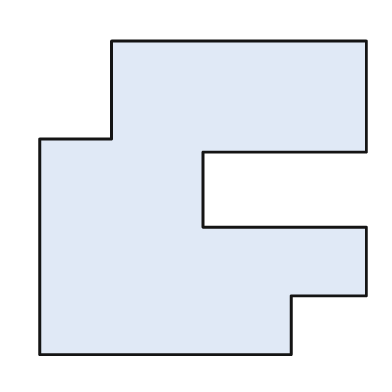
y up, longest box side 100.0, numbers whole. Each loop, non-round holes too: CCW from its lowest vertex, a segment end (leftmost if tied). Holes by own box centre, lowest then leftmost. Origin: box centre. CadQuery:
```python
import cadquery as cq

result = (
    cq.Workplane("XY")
    .moveTo(-50.0, -48.0)
    .lineTo(27.0, -48.0)
    .lineTo(27.0, -30.0)
    .lineTo(50.0, -30.0)
    .lineTo(50.0, -9.0)
    .lineTo(0.0, -9.0)
    .lineTo(0.0, 14.0)
    .lineTo(50.0, 14.0)
    .lineTo(50.0, 48.0)
    .lineTo(-28.0, 48.0)
    .lineTo(-28.0, 18.0)
    .lineTo(-50.0, 18.0)
    .close()
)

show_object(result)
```